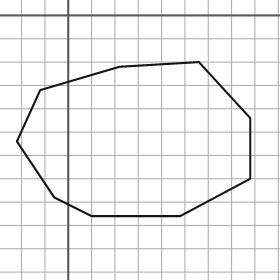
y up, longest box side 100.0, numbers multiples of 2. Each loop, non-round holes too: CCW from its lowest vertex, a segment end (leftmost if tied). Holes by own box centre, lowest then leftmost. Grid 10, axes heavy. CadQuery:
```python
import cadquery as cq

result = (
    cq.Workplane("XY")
    .moveTo(10.0, -86.0)
    .lineTo(48.0, -86.0)
    .lineTo(78.0, -70.0)
    .lineTo(78.0, -44.0)
    .lineTo(56.0, -20.0)
    .lineTo(22.0, -22.0)
    .lineTo(-12.0, -32.0)
    .lineTo(-22.0, -54.0)
    .lineTo(-6.0, -78.0)
    .close()
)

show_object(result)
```